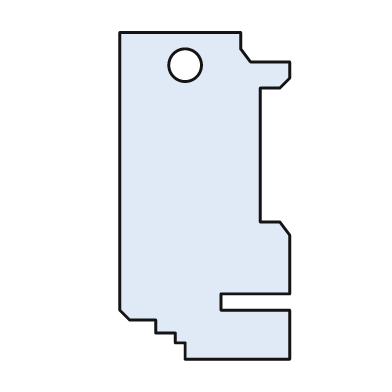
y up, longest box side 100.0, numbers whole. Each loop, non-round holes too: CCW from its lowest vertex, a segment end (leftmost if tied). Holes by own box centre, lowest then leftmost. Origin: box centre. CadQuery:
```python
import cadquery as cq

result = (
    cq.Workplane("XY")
    .moveTo(-6.0, -50.0)
    .lineTo(26.0, -50.0)
    .lineTo(26.0, -35.0)
    .lineTo(5.0, -35.0)
    .lineTo(5.0, -30.0)
    .lineTo(26.0, -30.0)
    .lineTo(26.0, -12.0)
    .lineTo(23.0, -8.0)
    .lineTo(17.0, -8.0)
    .lineTo(17.0, 33.0)
    .lineTo(23.0, 33.0)
    .lineTo(26.0, 36.0)
    .lineTo(26.0, 41.0)
    .lineTo(14.0, 41.0)
    .lineTo(11.0, 45.0)
    .lineTo(11.0, 50.0)
    .lineTo(-26.0, 50.0)
    .lineTo(-26.0, -35.0)
    .lineTo(-23.0, -38.0)
    .lineTo(-15.0, -38.0)
    .lineTo(-15.0, -42.0)
    .lineTo(-9.0, -42.0)
    .lineTo(-9.0, -45.0)
    .lineTo(-6.0, -45.0)
    .close()
    .moveTo(-6.0, 40.0)
    .circle(5.0)
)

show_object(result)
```